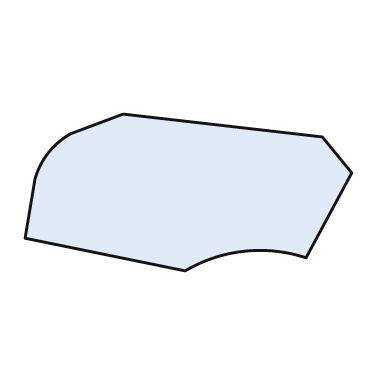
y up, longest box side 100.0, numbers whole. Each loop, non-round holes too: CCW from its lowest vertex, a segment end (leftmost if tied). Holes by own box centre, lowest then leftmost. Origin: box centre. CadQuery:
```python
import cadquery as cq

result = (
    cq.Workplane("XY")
    .moveTo(-1.0, -24.0)
    .threePointArc((17.0, -18.0), (36.0, -20.0))
    .lineTo(50.0, 6.0)
    .lineTo(41.0, 17.0)
    .lineTo(-20.0, 24.0)
    .lineTo(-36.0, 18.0)
    .threePointArc((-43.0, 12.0), (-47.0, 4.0))
    .lineTo(-50.0, -14.0)
    .close()
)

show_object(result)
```